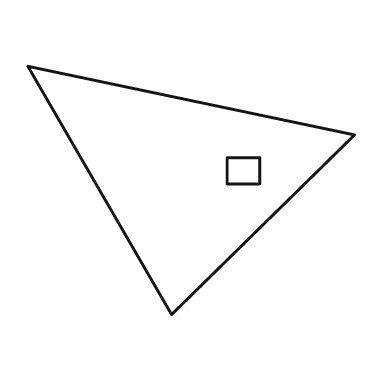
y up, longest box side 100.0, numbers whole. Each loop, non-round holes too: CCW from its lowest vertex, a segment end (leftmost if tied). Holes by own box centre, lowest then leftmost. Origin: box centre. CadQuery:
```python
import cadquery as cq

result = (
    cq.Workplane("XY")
    .moveTo(-6.0, -38.0)
    .lineTo(50.0, 17.0)
    .lineTo(-50.0, 38.0)
    .close()
    .moveTo(11.0, 2.0)
    .lineTo(21.0, 2.0)
    .lineTo(21.0, 10.0)
    .lineTo(11.0, 10.0)
    .close()
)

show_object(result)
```